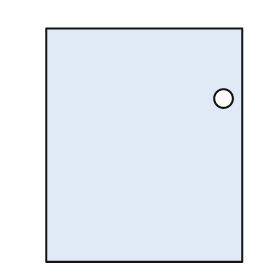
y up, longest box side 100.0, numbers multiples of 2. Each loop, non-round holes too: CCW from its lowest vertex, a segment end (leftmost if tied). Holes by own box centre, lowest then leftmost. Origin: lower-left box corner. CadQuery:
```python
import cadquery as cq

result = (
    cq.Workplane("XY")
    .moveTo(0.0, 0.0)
    .lineTo(84.0, 0.0)
    .lineTo(84.0, 100.0)
    .lineTo(0.0, 100.0)
    .close()
    .moveTo(76.0, 70.0)
    .circle(4.0)
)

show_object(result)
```